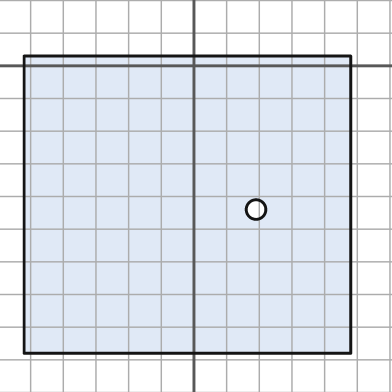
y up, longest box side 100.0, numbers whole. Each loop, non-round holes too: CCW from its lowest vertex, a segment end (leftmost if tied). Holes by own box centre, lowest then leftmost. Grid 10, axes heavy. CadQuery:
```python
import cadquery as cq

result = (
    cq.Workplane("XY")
    .moveTo(-52.0, -88.0)
    .lineTo(48.0, -88.0)
    .lineTo(48.0, 3.0)
    .lineTo(-52.0, 3.0)
    .close()
    .moveTo(19.0, -44.0)
    .circle(3.0)
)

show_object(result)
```